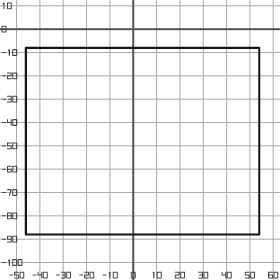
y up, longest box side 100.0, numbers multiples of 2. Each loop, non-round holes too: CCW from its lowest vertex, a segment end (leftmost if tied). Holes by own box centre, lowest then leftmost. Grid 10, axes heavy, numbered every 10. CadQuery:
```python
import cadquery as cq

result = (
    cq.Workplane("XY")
    .moveTo(-46.0, -88.0)
    .lineTo(54.0, -88.0)
    .lineTo(54.0, -8.0)
    .lineTo(-46.0, -8.0)
    .close()
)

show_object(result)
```